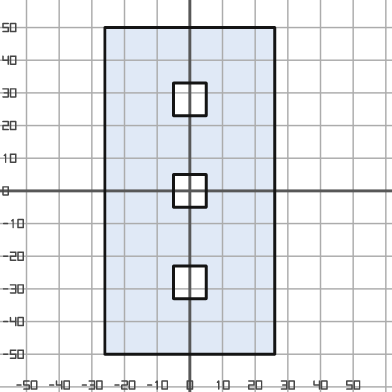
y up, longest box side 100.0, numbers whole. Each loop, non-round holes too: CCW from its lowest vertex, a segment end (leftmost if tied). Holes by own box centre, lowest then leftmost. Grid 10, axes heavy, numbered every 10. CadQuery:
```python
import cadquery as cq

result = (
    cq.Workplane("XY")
    .moveTo(-26.0, -50.0)
    .lineTo(26.0, -50.0)
    .lineTo(26.0, 50.0)
    .lineTo(-26.0, 50.0)
    .close()
    .moveTo(-5.0, -33.0)
    .lineTo(5.0, -33.0)
    .lineTo(5.0, -23.0)
    .lineTo(-5.0, -23.0)
    .close()
    .moveTo(-5.0, -5.0)
    .lineTo(5.0, -5.0)
    .lineTo(5.0, 5.0)
    .lineTo(-5.0, 5.0)
    .close()
    .moveTo(-5.0, 23.0)
    .lineTo(5.0, 23.0)
    .lineTo(5.0, 33.0)
    .lineTo(-5.0, 33.0)
    .close()
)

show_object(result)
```